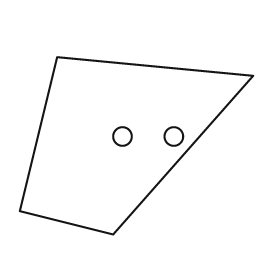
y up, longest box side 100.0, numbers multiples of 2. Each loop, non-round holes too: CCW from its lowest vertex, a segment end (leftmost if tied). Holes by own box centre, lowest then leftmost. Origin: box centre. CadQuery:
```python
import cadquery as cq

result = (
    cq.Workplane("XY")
    .moveTo(-10.0, -38.0)
    .lineTo(50.0, 30.0)
    .lineTo(-34.0, 38.0)
    .lineTo(-50.0, -28.0)
    .close()
    .moveTo(-6.0, 4.0)
    .circle(4.0)
    .moveTo(16.0, 4.0)
    .circle(4.0)
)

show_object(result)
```